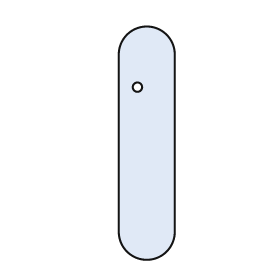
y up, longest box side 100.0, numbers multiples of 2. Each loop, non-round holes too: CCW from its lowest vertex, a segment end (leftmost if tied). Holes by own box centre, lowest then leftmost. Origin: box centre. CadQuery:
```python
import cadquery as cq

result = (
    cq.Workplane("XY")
    .moveTo(-12.0, -38.0)
    .threePointArc((0.0, -50.0), (12.0, -38.0))
    .lineTo(12.0, 38.0)
    .threePointArc((0.0, 50.0), (-12.0, 38.0))
    .close()
    .moveTo(-4.0, 24.0)
    .circle(2.0)
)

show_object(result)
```